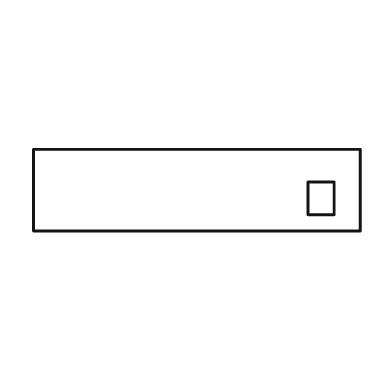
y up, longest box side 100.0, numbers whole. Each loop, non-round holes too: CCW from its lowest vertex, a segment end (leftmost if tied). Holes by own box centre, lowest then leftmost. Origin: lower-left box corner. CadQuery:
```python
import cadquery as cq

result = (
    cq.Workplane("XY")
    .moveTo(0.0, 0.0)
    .lineTo(100.0, 0.0)
    .lineTo(100.0, 25.0)
    .lineTo(0.0, 25.0)
    .close()
    .moveTo(84.0, 5.0)
    .lineTo(92.0, 5.0)
    .lineTo(92.0, 15.0)
    .lineTo(84.0, 15.0)
    .close()
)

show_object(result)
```